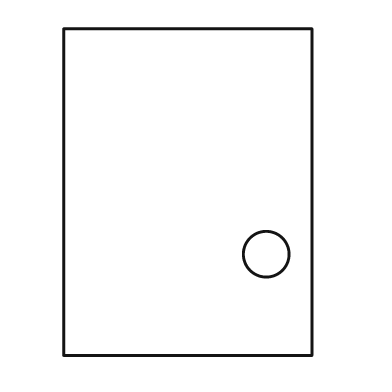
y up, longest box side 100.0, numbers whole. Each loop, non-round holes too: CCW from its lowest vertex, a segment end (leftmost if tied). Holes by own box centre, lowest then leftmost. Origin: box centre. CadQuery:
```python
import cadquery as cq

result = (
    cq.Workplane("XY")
    .moveTo(-38.0, -50.0)
    .lineTo(38.0, -50.0)
    .lineTo(38.0, 50.0)
    .lineTo(-38.0, 50.0)
    .close()
    .moveTo(24.0, -19.0)
    .circle(7.0)
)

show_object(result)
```